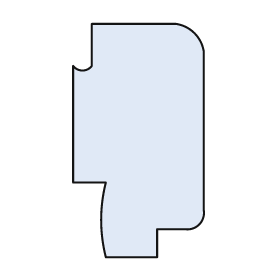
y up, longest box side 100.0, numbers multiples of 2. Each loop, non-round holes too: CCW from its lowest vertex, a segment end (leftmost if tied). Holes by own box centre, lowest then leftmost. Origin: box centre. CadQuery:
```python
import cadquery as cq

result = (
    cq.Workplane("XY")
    .moveTo(-14.0, -50.0)
    .lineTo(8.0, -50.0)
    .lineTo(8.0, -38.0)
    .lineTo(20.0, -38.0)
    .threePointArc((26.0, -36.0), (28.0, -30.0))
    .lineTo(28.0, 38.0)
    .threePointArc((24.0, 46.0), (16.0, 50.0))
    .lineTo(-20.0, 50.0)
    .lineTo(-20.0, 32.0)
    .threePointArc((-24.0, 30.0), (-28.0, 32.0))
    .lineTo(-28.0, -18.0)
    .lineTo(-14.0, -18.0)
    .threePointArc((-16.0, -34.0), (-14.0, -50.0))
    .close()
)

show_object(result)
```